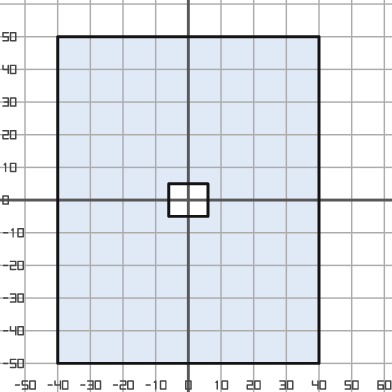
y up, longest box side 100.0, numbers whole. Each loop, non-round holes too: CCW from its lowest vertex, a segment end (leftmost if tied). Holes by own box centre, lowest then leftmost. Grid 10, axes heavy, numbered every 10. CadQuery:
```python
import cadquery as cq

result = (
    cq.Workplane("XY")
    .moveTo(-40.0, -50.0)
    .lineTo(40.0, -50.0)
    .lineTo(40.0, 50.0)
    .lineTo(-40.0, 50.0)
    .close()
    .moveTo(-6.0, -5.0)
    .lineTo(6.0, -5.0)
    .lineTo(6.0, 5.0)
    .lineTo(-6.0, 5.0)
    .close()
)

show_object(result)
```